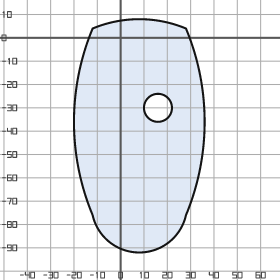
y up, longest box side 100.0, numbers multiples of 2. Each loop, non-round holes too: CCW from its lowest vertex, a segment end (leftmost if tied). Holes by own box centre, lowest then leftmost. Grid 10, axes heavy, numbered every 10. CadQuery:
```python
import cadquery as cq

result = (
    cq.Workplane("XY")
    .moveTo(-12.0, -76.0)
    .threePointArc((8.0, -92.0), (28.0, -76.0))
    .threePointArc((36.0, -36.0), (28.0, 4.0))
    .threePointArc((8.0, 8.0), (-12.0, 4.0))
    .threePointArc((-20.0, -36.0), (-12.0, -76.0))
    .close()
    .moveTo(16.0, -30.0)
    .circle(6.0)
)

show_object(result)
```